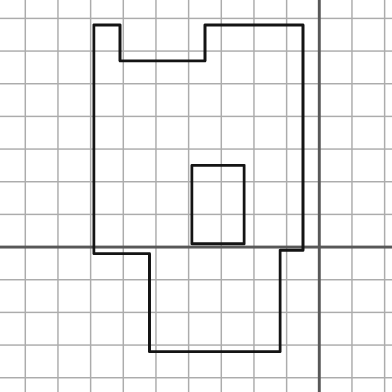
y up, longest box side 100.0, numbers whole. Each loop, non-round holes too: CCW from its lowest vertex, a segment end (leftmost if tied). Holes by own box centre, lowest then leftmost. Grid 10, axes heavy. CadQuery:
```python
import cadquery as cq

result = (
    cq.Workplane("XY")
    .moveTo(-52.0, -32.0)
    .lineTo(-12.0, -32.0)
    .lineTo(-12.0, -1.0)
    .lineTo(-5.0, -1.0)
    .lineTo(-5.0, 68.0)
    .lineTo(-35.0, 68.0)
    .lineTo(-35.0, 57.0)
    .lineTo(-61.0, 57.0)
    .lineTo(-61.0, 68.0)
    .lineTo(-69.0, 68.0)
    .lineTo(-69.0, -2.0)
    .lineTo(-52.0, -2.0)
    .close()
    .moveTo(-39.0, 1.0)
    .lineTo(-23.0, 1.0)
    .lineTo(-23.0, 25.0)
    .lineTo(-39.0, 25.0)
    .close()
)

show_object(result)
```